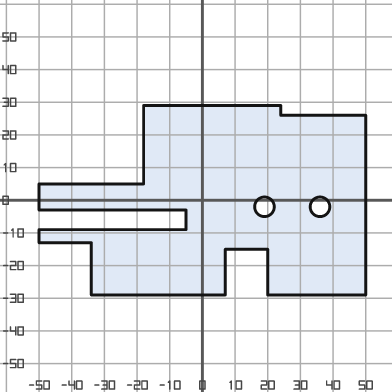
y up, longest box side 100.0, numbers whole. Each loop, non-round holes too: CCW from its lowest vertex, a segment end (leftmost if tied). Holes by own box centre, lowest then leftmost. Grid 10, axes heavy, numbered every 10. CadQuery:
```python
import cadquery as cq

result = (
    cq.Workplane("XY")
    .moveTo(-34.0, -29.0)
    .lineTo(7.0, -29.0)
    .lineTo(7.0, -15.0)
    .lineTo(20.0, -15.0)
    .lineTo(20.0, -29.0)
    .lineTo(50.0, -29.0)
    .lineTo(50.0, 26.0)
    .lineTo(24.0, 26.0)
    .lineTo(24.0, 29.0)
    .lineTo(-18.0, 29.0)
    .lineTo(-18.0, 5.0)
    .lineTo(-50.0, 5.0)
    .lineTo(-50.0, -3.0)
    .lineTo(-5.0, -3.0)
    .lineTo(-5.0, -9.0)
    .lineTo(-50.0, -9.0)
    .lineTo(-50.0, -13.0)
    .lineTo(-34.0, -13.0)
    .close()
    .moveTo(19.0, -2.0)
    .circle(3.0)
    .moveTo(36.0, -2.0)
    .circle(3.0)
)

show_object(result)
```